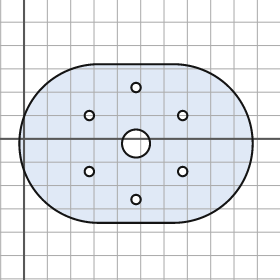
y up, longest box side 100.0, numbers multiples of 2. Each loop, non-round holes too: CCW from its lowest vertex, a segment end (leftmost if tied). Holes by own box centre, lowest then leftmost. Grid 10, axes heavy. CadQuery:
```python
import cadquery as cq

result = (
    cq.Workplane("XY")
    .moveTo(32.0, -36.0)
    .lineTo(64.0, -36.0)
    .threePointArc((98.0, -2.0), (64.0, 32.0))
    .lineTo(32.0, 32.0)
    .threePointArc((-2.0, -2.0), (32.0, -36.0))
    .close()
    .moveTo(48.0, -26.0)
    .circle(2.0)
    .moveTo(28.0, -14.0)
    .circle(2.0)
    .moveTo(68.0, -14.0)
    .circle(2.0)
    .moveTo(48.0, -2.0)
    .circle(6.0)
    .moveTo(28.0, 10.0)
    .circle(2.0)
    .moveTo(68.0, 10.0)
    .circle(2.0)
    .moveTo(48.0, 22.0)
    .circle(2.0)
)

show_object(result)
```